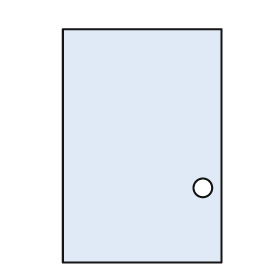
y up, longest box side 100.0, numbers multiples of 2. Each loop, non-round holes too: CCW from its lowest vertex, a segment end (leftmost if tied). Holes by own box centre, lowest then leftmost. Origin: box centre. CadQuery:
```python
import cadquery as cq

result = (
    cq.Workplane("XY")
    .moveTo(-34.0, -50.0)
    .lineTo(34.0, -50.0)
    .lineTo(34.0, 50.0)
    .lineTo(-34.0, 50.0)
    .close()
    .moveTo(26.0, -18.0)
    .circle(4.0)
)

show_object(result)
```